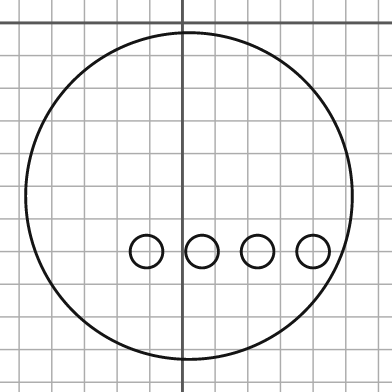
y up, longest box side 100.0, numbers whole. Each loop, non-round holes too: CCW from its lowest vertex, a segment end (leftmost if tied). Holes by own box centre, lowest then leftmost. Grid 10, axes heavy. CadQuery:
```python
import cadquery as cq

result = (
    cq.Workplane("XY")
    .moveTo(2.0, -53.0)
    .circle(50.0)
    .moveTo(-11.0, -70.0)
    .circle(5.0)
    .moveTo(6.0, -70.0)
    .circle(5.0)
    .moveTo(23.0, -70.0)
    .circle(5.0)
    .moveTo(40.0, -70.0)
    .circle(5.0)
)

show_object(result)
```